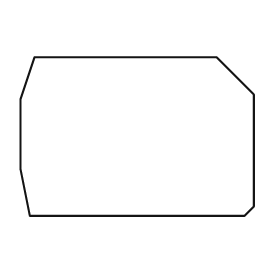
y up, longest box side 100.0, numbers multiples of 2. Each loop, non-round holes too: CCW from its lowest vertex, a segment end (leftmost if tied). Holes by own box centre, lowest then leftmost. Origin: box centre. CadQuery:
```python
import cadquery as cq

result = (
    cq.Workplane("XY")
    .moveTo(-46.0, -34.0)
    .lineTo(46.0, -34.0)
    .lineTo(50.0, -30.0)
    .lineTo(50.0, 18.0)
    .lineTo(34.0, 34.0)
    .lineTo(-44.0, 34.0)
    .lineTo(-50.0, 16.0)
    .lineTo(-50.0, -14.0)
    .close()
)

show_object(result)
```